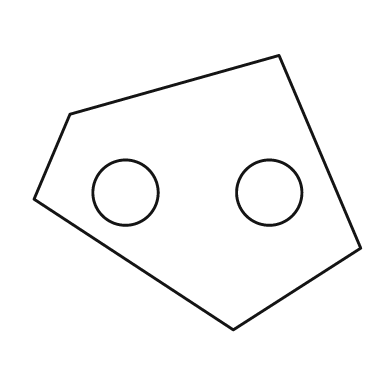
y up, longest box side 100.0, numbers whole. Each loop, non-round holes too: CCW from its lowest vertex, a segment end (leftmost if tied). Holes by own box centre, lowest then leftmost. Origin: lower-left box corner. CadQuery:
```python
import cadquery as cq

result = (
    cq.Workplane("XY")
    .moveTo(61.0, 0.0)
    .lineTo(100.0, 25.0)
    .lineTo(75.0, 84.0)
    .lineTo(11.0, 66.0)
    .lineTo(0.0, 40.0)
    .close()
    .moveTo(28.0, 42.0)
    .circle(10.0)
    .moveTo(72.0, 42.0)
    .circle(10.0)
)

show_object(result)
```